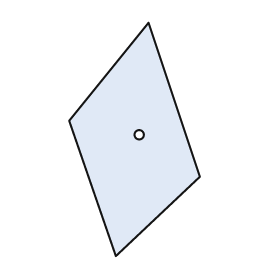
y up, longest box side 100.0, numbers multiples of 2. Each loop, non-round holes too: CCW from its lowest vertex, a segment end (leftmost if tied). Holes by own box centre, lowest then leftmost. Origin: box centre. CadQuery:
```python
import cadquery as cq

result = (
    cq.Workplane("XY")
    .moveTo(-8.0, -50.0)
    .lineTo(28.0, -16.0)
    .lineTo(6.0, 50.0)
    .lineTo(-28.0, 8.0)
    .close()
    .moveTo(2.0, 2.0)
    .circle(2.0)
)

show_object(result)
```